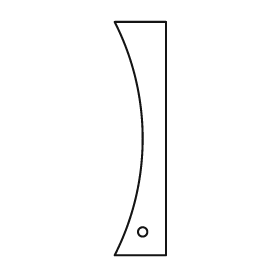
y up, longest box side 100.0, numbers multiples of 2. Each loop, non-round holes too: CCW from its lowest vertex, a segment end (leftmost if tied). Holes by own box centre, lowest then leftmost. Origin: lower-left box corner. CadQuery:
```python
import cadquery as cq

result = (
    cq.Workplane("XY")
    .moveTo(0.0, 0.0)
    .lineTo(22.0, 0.0)
    .lineTo(22.0, 100.0)
    .lineTo(0.0, 100.0)
    .threePointArc((12.0, 50.0), (0.0, 0.0))
    .close()
    .moveTo(12.0, 10.0)
    .circle(2.0)
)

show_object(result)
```